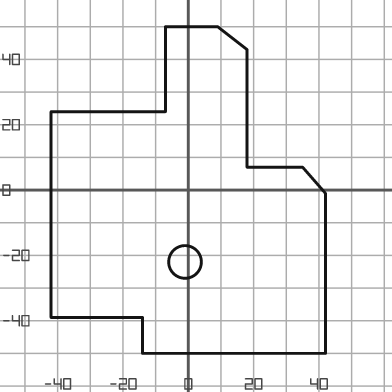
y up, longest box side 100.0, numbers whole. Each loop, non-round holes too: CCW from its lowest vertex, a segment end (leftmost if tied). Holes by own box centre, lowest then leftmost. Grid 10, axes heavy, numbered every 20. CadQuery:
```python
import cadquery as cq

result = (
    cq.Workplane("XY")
    .moveTo(-14.0, -50.0)
    .lineTo(42.0, -50.0)
    .lineTo(42.0, -1.0)
    .lineTo(35.0, 7.0)
    .lineTo(18.0, 7.0)
    .lineTo(18.0, 43.0)
    .lineTo(9.0, 50.0)
    .lineTo(-7.0, 50.0)
    .lineTo(-7.0, 24.0)
    .lineTo(-42.0, 24.0)
    .lineTo(-42.0, -39.0)
    .lineTo(-14.0, -39.0)
    .close()
    .moveTo(-1.0, -22.0)
    .circle(5.0)
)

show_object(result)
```